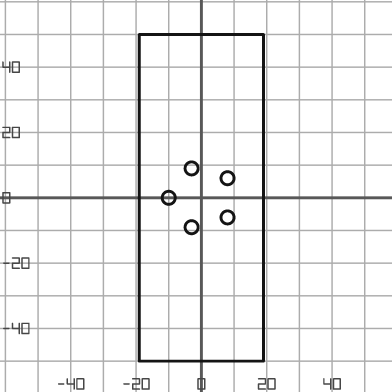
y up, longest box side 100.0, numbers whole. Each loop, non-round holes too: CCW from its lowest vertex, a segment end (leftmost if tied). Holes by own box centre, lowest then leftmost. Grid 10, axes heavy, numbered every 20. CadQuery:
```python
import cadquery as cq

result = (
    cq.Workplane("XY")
    .moveTo(-19.0, -50.0)
    .lineTo(19.0, -50.0)
    .lineTo(19.0, 50.0)
    .lineTo(-19.0, 50.0)
    .close()
    .moveTo(-3.0, -9.0)
    .circle(2.0)
    .moveTo(8.0, -6.0)
    .circle(2.0)
    .moveTo(-10.0, 0.0)
    .circle(2.0)
    .moveTo(8.0, 6.0)
    .circle(2.0)
    .moveTo(-3.0, 9.0)
    .circle(2.0)
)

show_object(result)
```